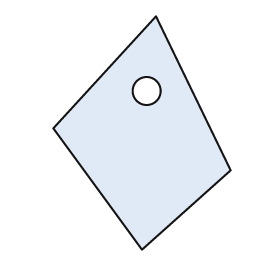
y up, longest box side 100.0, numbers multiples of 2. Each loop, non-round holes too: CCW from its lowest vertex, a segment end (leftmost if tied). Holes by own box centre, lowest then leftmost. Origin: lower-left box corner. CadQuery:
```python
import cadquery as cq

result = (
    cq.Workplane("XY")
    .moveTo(38.0, 0.0)
    .lineTo(76.0, 34.0)
    .lineTo(44.0, 100.0)
    .lineTo(0.0, 52.0)
    .close()
    .moveTo(40.0, 68.0)
    .circle(6.0)
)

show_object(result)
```